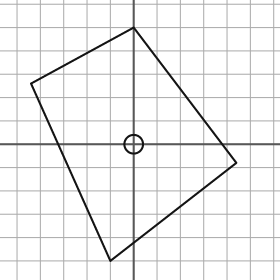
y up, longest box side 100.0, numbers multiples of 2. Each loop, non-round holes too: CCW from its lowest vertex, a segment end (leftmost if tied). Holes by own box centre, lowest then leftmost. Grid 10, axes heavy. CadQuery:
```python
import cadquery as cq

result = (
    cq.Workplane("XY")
    .moveTo(-10.0, -50.0)
    .lineTo(44.0, -8.0)
    .lineTo(0.0, 50.0)
    .lineTo(-44.0, 26.0)
    .close()
    .moveTo(0.0, 0.0)
    .circle(4.0)
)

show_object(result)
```